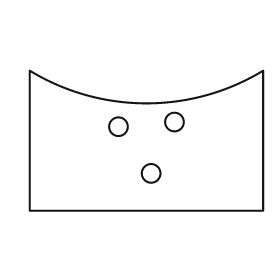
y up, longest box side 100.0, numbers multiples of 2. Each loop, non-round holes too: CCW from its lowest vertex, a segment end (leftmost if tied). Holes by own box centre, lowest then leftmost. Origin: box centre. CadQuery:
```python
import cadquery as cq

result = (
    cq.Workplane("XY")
    .moveTo(-50.0, -30.0)
    .lineTo(50.0, -30.0)
    .lineTo(50.0, 30.0)
    .threePointArc((0.0, 16.0), (-50.0, 30.0))
    .close()
    .moveTo(2.0, -14.0)
    .circle(4.0)
    .moveTo(-12.0, 6.0)
    .circle(4.0)
    .moveTo(12.0, 8.0)
    .circle(4.0)
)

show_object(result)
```